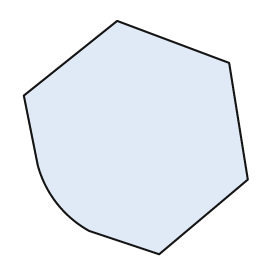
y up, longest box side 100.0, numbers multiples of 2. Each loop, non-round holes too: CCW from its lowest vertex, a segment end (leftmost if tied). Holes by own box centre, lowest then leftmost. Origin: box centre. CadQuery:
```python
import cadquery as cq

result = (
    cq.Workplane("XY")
    .moveTo(10.0, -50.0)
    .lineTo(48.0, -18.0)
    .lineTo(40.0, 32.0)
    .lineTo(-8.0, 50.0)
    .lineTo(-48.0, 18.0)
    .lineTo(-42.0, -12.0)
    .threePointArc((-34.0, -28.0), (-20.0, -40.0))
    .close()
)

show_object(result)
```